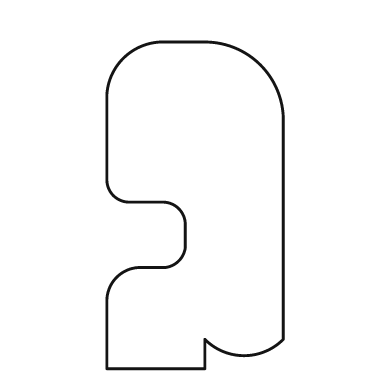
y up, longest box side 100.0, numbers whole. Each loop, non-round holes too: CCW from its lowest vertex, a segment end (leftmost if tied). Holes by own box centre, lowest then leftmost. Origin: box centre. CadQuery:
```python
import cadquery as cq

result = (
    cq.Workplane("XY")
    .moveTo(-27.0, -50.0)
    .lineTo(3.0, -50.0)
    .lineTo(3.0, -41.0)
    .threePointArc((15.0, -46.0), (27.0, -41.0))
    .lineTo(27.0, 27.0)
    .threePointArc((20.0, 43.0), (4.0, 50.0))
    .lineTo(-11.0, 50.0)
    .threePointArc((-22.0, 45.0), (-27.0, 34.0))
    .lineTo(-27.0, 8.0)
    .threePointArc((-25.0, 3.0), (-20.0, 1.0))
    .lineTo(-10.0, 1.0)
    .threePointArc((-5.0, -1.0), (-3.0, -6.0))
    .lineTo(-3.0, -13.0)
    .threePointArc((-5.0, -17.0), (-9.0, -19.0))
    .lineTo(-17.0, -19.0)
    .threePointArc((-24.0, -22.0), (-27.0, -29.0))
    .close()
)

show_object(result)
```